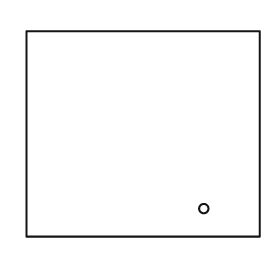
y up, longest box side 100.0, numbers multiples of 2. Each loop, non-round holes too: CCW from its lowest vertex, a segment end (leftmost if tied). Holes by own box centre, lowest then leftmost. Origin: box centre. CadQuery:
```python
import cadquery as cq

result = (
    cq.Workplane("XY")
    .moveTo(-50.0, -44.0)
    .lineTo(50.0, -44.0)
    .lineTo(50.0, 44.0)
    .lineTo(-50.0, 44.0)
    .close()
    .moveTo(26.0, -32.0)
    .circle(2.0)
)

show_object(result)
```